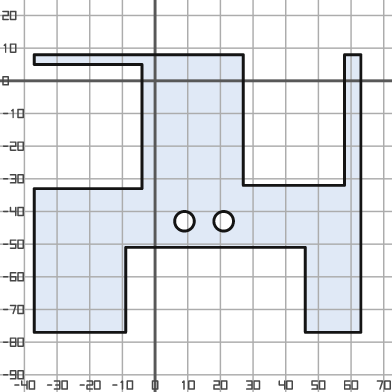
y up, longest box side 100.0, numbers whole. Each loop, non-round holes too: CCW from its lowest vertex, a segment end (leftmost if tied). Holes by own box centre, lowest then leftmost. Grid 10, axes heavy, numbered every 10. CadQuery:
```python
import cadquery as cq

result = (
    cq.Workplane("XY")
    .moveTo(-37.0, -77.0)
    .lineTo(-9.0, -77.0)
    .lineTo(-9.0, -51.0)
    .lineTo(46.0, -51.0)
    .lineTo(46.0, -77.0)
    .lineTo(63.0, -77.0)
    .lineTo(63.0, 8.0)
    .lineTo(58.0, 8.0)
    .lineTo(58.0, -32.0)
    .lineTo(27.0, -32.0)
    .lineTo(27.0, 8.0)
    .lineTo(-37.0, 8.0)
    .lineTo(-37.0, 5.0)
    .lineTo(-4.0, 5.0)
    .lineTo(-4.0, -33.0)
    .lineTo(-37.0, -33.0)
    .close()
    .moveTo(9.0, -43.0)
    .circle(3.0)
    .moveTo(21.0, -43.0)
    .circle(3.0)
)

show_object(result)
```